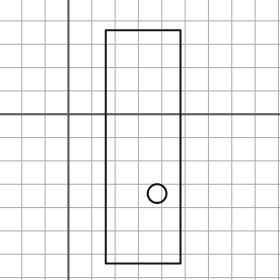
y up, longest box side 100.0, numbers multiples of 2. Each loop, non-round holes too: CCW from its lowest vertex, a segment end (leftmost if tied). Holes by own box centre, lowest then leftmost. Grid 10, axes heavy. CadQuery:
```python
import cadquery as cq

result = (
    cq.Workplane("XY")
    .moveTo(16.0, -64.0)
    .lineTo(48.0, -64.0)
    .lineTo(48.0, 36.0)
    .lineTo(16.0, 36.0)
    .close()
    .moveTo(38.0, -34.0)
    .circle(4.0)
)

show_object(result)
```